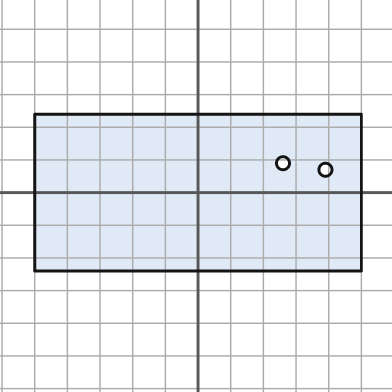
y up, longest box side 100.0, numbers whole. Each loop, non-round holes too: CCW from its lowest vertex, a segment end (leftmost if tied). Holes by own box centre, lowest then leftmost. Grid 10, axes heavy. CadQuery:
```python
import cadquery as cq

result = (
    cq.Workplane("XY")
    .moveTo(-50.0, -24.0)
    .lineTo(50.0, -24.0)
    .lineTo(50.0, 24.0)
    .lineTo(-50.0, 24.0)
    .close()
    .moveTo(39.0, 7.0)
    .circle(2.0)
    .moveTo(26.0, 9.0)
    .circle(2.0)
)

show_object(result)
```